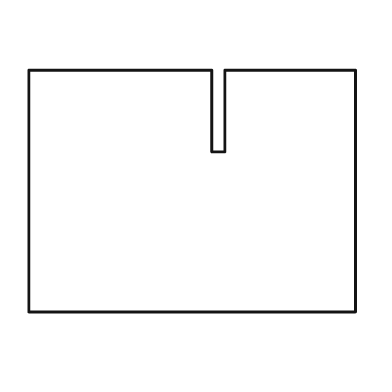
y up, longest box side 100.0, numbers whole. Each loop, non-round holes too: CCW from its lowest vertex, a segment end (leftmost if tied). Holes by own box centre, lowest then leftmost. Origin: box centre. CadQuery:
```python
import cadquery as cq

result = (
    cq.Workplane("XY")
    .moveTo(-50.0, -37.0)
    .lineTo(50.0, -37.0)
    .lineTo(50.0, 37.0)
    .lineTo(10.0, 37.0)
    .lineTo(10.0, 12.0)
    .lineTo(6.0, 12.0)
    .lineTo(6.0, 37.0)
    .lineTo(-50.0, 37.0)
    .close()
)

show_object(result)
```